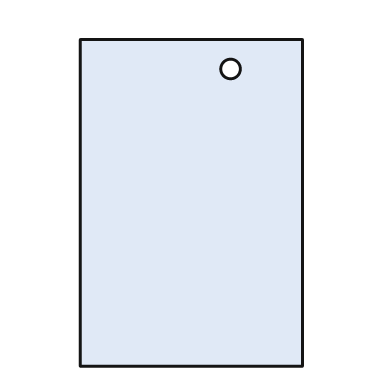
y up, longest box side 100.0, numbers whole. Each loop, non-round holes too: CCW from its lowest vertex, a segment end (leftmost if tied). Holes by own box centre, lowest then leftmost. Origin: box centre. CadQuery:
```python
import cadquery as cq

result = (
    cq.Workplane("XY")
    .moveTo(-34.0, -50.0)
    .lineTo(34.0, -50.0)
    .lineTo(34.0, 50.0)
    .lineTo(-34.0, 50.0)
    .close()
    .moveTo(12.0, 41.0)
    .circle(3.0)
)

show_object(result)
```